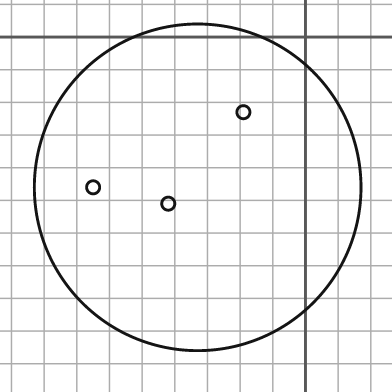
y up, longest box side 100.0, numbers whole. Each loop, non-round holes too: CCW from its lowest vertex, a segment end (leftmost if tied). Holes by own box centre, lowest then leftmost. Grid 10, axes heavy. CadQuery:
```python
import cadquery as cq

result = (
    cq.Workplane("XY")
    .moveTo(-33.0, -46.0)
    .circle(50.0)
    .moveTo(-42.0, -51.0)
    .circle(2.0)
    .moveTo(-65.0, -46.0)
    .circle(2.0)
    .moveTo(-19.0, -23.0)
    .circle(2.0)
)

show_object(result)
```